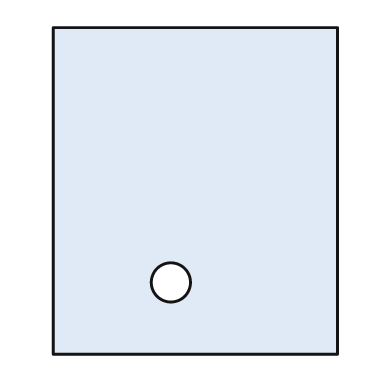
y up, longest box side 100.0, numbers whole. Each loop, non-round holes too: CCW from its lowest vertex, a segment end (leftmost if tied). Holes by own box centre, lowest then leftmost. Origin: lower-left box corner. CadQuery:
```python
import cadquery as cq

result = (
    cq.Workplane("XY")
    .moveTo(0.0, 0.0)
    .lineTo(87.0, 0.0)
    .lineTo(87.0, 100.0)
    .lineTo(0.0, 100.0)
    .close()
    .moveTo(36.0, 22.0)
    .circle(6.0)
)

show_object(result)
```